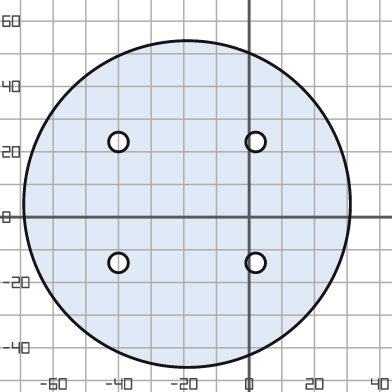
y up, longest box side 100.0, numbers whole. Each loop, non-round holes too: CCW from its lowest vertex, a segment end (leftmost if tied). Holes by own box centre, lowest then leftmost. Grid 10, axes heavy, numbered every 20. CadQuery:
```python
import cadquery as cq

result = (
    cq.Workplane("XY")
    .moveTo(-19.0, 4.0)
    .circle(50.0)
    .moveTo(-40.0, -14.0)
    .circle(3.0)
    .moveTo(2.0, -14.0)
    .circle(3.0)
    .moveTo(-40.0, 23.0)
    .circle(3.0)
    .moveTo(2.0, 23.0)
    .circle(3.0)
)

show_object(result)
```